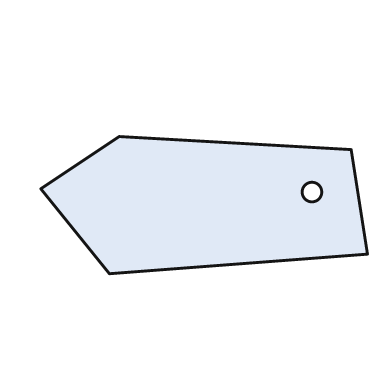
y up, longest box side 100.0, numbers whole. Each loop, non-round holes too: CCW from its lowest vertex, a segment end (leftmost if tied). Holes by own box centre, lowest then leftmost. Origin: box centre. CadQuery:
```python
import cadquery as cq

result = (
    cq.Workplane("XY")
    .moveTo(-29.0, -21.0)
    .lineTo(50.0, -15.0)
    .lineTo(45.0, 17.0)
    .lineTo(-26.0, 21.0)
    .lineTo(-50.0, 5.0)
    .close()
    .moveTo(33.0, 4.0)
    .circle(3.0)
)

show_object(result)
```